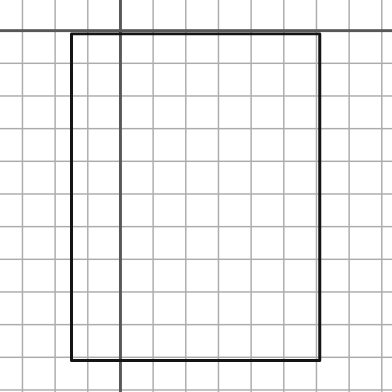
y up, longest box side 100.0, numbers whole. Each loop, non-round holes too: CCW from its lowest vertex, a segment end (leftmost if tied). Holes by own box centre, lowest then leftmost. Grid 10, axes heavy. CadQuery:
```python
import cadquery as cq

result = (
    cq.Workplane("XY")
    .moveTo(-15.0, -101.0)
    .lineTo(61.0, -101.0)
    .lineTo(61.0, -1.0)
    .lineTo(-15.0, -1.0)
    .close()
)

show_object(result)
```